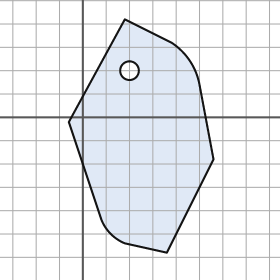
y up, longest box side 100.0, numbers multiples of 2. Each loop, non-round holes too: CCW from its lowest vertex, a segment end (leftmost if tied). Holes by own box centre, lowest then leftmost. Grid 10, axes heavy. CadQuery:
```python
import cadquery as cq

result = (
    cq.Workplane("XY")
    .moveTo(36.0, -58.0)
    .lineTo(56.0, -18.0)
    .lineTo(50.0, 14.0)
    .threePointArc((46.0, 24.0), (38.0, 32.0))
    .lineTo(18.0, 42.0)
    .lineTo(-6.0, -2.0)
    .lineTo(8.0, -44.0)
    .threePointArc((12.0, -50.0), (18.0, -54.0))
    .close()
    .moveTo(20.0, 20.0)
    .circle(4.0)
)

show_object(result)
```